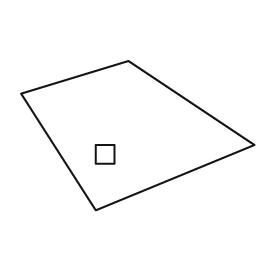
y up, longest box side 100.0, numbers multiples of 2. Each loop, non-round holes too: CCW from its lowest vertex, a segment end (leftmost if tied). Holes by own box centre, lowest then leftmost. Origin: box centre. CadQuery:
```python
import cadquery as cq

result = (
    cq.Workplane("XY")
    .moveTo(-18.0, -32.0)
    .lineTo(50.0, -4.0)
    .lineTo(-4.0, 32.0)
    .lineTo(-50.0, 18.0)
    .close()
    .moveTo(-18.0, -12.0)
    .lineTo(-10.0, -12.0)
    .lineTo(-10.0, -4.0)
    .lineTo(-18.0, -4.0)
    .close()
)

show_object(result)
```